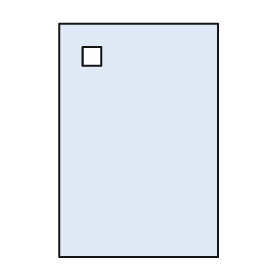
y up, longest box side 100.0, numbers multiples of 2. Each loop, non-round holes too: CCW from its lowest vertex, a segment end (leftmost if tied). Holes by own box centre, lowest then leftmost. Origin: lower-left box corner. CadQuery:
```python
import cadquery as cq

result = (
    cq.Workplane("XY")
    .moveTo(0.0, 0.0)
    .lineTo(68.0, 0.0)
    .lineTo(68.0, 100.0)
    .lineTo(0.0, 100.0)
    .close()
    .moveTo(10.0, 82.0)
    .lineTo(18.0, 82.0)
    .lineTo(18.0, 90.0)
    .lineTo(10.0, 90.0)
    .close()
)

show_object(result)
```